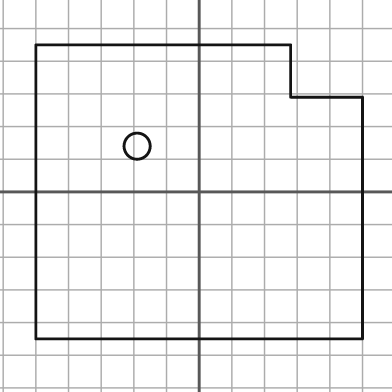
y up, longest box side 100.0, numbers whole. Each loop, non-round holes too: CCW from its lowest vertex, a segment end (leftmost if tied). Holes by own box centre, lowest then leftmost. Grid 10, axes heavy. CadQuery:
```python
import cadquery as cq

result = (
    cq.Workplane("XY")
    .moveTo(-50.0, -45.0)
    .lineTo(50.0, -45.0)
    .lineTo(50.0, 29.0)
    .lineTo(28.0, 29.0)
    .lineTo(28.0, 45.0)
    .lineTo(-50.0, 45.0)
    .close()
    .moveTo(-19.0, 14.0)
    .circle(4.0)
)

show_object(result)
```